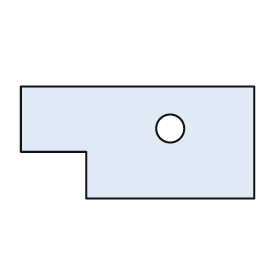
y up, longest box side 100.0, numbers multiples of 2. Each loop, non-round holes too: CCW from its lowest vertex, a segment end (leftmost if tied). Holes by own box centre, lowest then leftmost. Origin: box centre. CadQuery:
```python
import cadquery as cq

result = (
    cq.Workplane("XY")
    .moveTo(-22.0, -24.0)
    .lineTo(50.0, -24.0)
    .lineTo(50.0, 24.0)
    .lineTo(-50.0, 24.0)
    .lineTo(-50.0, -4.0)
    .lineTo(-22.0, -4.0)
    .close()
    .moveTo(14.0, 6.0)
    .circle(6.0)
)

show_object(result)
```